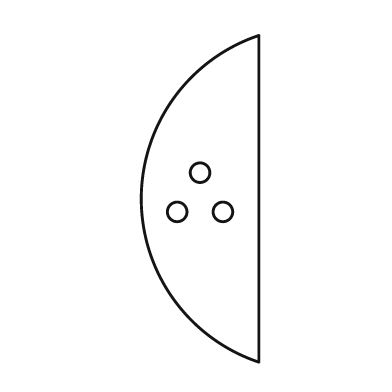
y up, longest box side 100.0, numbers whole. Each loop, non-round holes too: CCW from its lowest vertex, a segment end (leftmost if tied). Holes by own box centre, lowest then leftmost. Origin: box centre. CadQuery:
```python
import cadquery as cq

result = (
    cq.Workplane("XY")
    .moveTo(18.0, -50.0)
    .lineTo(18.0, 50.0)
    .threePointArc((-18.0, 0.0), (18.0, -50.0))
    .close()
    .moveTo(-7.0, -4.0)
    .circle(3.0)
    .moveTo(7.0, -4.0)
    .circle(3.0)
    .moveTo(0.0, 8.0)
    .circle(3.0)
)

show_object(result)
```